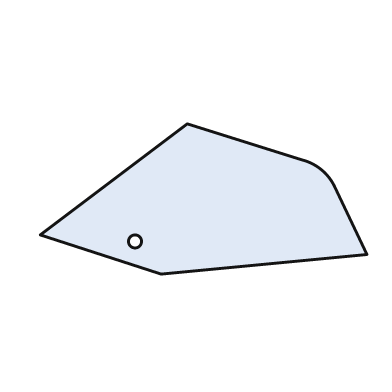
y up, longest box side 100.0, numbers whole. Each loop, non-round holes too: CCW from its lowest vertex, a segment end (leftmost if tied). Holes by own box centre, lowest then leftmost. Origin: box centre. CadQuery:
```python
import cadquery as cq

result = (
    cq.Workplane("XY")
    .moveTo(-13.0, -23.0)
    .lineTo(50.0, -17.0)
    .lineTo(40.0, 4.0)
    .threePointArc((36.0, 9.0), (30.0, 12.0))
    .lineTo(-5.0, 23.0)
    .lineTo(-50.0, -11.0)
    .close()
    .moveTo(-21.0, -13.0)
    .circle(2.0)
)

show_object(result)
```